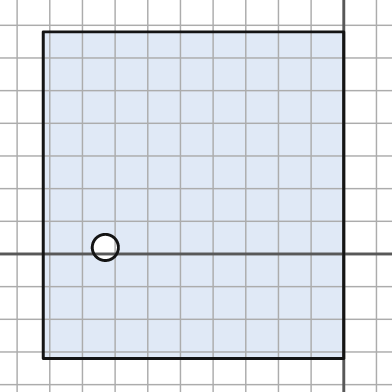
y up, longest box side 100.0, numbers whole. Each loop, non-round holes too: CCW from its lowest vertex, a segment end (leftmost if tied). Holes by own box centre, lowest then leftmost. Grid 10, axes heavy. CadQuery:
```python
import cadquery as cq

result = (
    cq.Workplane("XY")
    .moveTo(-92.0, -32.0)
    .lineTo(0.0, -32.0)
    .lineTo(0.0, 68.0)
    .lineTo(-92.0, 68.0)
    .close()
    .moveTo(-73.0, 2.0)
    .circle(4.0)
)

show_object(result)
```